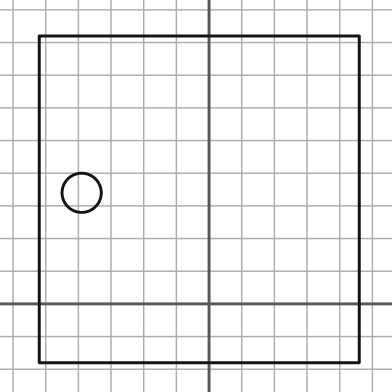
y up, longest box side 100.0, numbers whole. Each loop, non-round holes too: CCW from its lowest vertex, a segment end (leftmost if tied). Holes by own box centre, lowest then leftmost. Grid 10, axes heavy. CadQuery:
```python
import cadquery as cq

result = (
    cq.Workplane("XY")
    .moveTo(-52.0, -18.0)
    .lineTo(46.0, -18.0)
    .lineTo(46.0, 82.0)
    .lineTo(-52.0, 82.0)
    .close()
    .moveTo(-39.0, 34.0)
    .circle(6.0)
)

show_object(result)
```